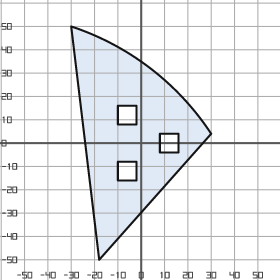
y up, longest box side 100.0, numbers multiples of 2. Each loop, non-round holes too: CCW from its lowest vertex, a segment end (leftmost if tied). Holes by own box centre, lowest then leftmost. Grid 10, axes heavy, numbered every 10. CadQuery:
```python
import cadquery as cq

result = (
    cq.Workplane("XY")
    .moveTo(-18.0, -50.0)
    .lineTo(30.0, 4.0)
    .threePointArc((4.0, 32.0), (-30.0, 50.0))
    .close()
    .moveTo(-10.0, -16.0)
    .lineTo(-2.0, -16.0)
    .lineTo(-2.0, -8.0)
    .lineTo(-10.0, -8.0)
    .close()
    .moveTo(8.0, -4.0)
    .lineTo(16.0, -4.0)
    .lineTo(16.0, 4.0)
    .lineTo(8.0, 4.0)
    .close()
    .moveTo(-10.0, 8.0)
    .lineTo(-2.0, 8.0)
    .lineTo(-2.0, 16.0)
    .lineTo(-10.0, 16.0)
    .close()
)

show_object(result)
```